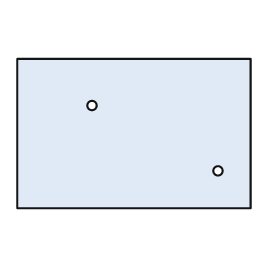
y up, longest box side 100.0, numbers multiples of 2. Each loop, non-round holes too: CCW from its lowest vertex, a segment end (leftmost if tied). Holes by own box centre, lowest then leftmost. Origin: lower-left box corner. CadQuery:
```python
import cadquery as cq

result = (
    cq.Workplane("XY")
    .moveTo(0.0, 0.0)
    .lineTo(100.0, 0.0)
    .lineTo(100.0, 64.0)
    .lineTo(0.0, 64.0)
    .close()
    .moveTo(86.0, 16.0)
    .circle(2.0)
    .moveTo(32.0, 44.0)
    .circle(2.0)
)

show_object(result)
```